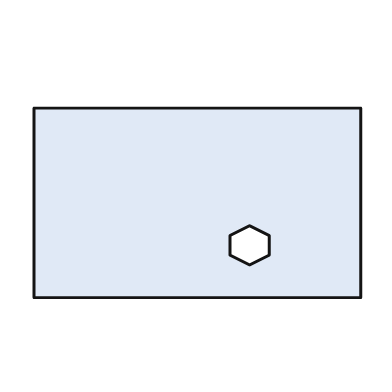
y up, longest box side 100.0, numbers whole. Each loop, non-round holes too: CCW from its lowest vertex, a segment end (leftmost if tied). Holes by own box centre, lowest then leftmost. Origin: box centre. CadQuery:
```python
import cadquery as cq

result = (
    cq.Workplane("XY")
    .moveTo(-50.0, -29.0)
    .lineTo(50.0, -29.0)
    .lineTo(50.0, 29.0)
    .lineTo(-50.0, 29.0)
    .close()
    .moveTo(16.0, -19.0)
    .lineTo(22.0, -16.0)
    .lineTo(22.0, -10.0)
    .lineTo(16.0, -7.0)
    .lineTo(10.0, -10.0)
    .lineTo(10.0, -16.0)
    .close()
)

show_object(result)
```